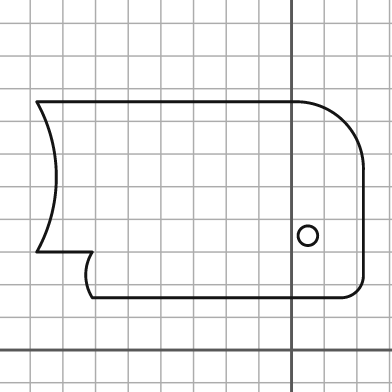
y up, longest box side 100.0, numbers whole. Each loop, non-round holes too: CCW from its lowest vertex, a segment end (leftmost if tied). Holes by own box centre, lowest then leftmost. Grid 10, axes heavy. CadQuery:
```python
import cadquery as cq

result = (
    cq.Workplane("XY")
    .moveTo(-61.0, 16.0)
    .lineTo(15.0, 16.0)
    .threePointArc((20.0, 18.0), (22.0, 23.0))
    .lineTo(22.0, 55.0)
    .threePointArc((16.0, 70.0), (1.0, 76.0))
    .lineTo(-78.0, 76.0)
    .threePointArc((-72.0, 53.0), (-78.0, 30.0))
    .lineTo(-61.0, 30.0)
    .threePointArc((-63.0, 23.0), (-61.0, 16.0))
    .close()
    .moveTo(5.0, 35.0)
    .circle(3.0)
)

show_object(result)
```